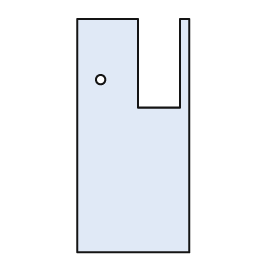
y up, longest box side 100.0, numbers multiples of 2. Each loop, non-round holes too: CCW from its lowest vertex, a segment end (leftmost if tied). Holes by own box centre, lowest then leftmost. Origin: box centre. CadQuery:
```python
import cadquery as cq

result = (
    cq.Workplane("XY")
    .moveTo(-24.0, -50.0)
    .lineTo(24.0, -50.0)
    .lineTo(24.0, 50.0)
    .lineTo(20.0, 50.0)
    .lineTo(20.0, 12.0)
    .lineTo(2.0, 12.0)
    .lineTo(2.0, 50.0)
    .lineTo(-24.0, 50.0)
    .close()
    .moveTo(-14.0, 24.0)
    .circle(2.0)
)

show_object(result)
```